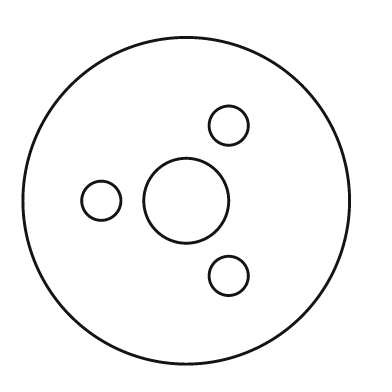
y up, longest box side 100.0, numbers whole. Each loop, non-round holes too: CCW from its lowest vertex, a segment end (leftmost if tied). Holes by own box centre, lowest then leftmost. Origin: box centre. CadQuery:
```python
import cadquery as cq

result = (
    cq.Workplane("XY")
    .moveTo(0.0, 0.0)
    .circle(50.0)
    .moveTo(13.0, -23.0)
    .circle(6.0)
    .moveTo(-26.0, 0.0)
    .circle(6.0)
    .moveTo(0.0, 0.0)
    .circle(13.0)
    .moveTo(13.0, 23.0)
    .circle(6.0)
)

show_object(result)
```